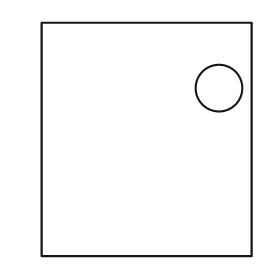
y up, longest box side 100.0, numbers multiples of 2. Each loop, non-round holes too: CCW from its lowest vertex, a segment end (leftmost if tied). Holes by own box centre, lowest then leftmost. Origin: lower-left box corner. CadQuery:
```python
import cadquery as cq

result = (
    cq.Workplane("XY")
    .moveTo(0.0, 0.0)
    .lineTo(90.0, 0.0)
    .lineTo(90.0, 100.0)
    .lineTo(0.0, 100.0)
    .close()
    .moveTo(76.0, 72.0)
    .circle(10.0)
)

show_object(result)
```